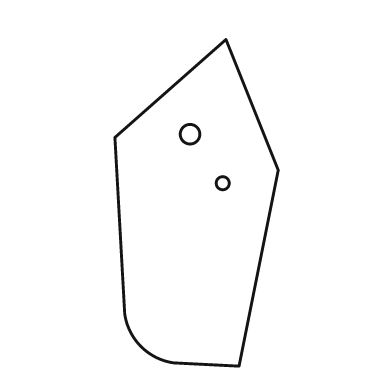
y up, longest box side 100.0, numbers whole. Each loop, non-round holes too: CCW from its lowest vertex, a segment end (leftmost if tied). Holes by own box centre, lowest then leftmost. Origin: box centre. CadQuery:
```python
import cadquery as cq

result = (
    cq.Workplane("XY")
    .moveTo(13.0, -50.0)
    .lineTo(25.0, 10.0)
    .lineTo(9.0, 50.0)
    .lineTo(-25.0, 20.0)
    .lineTo(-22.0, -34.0)
    .threePointArc((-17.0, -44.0), (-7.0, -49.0))
    .close()
    .moveTo(8.0, 6.0)
    .circle(2.0)
    .moveTo(-2.0, 21.0)
    .circle(3.0)
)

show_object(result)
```